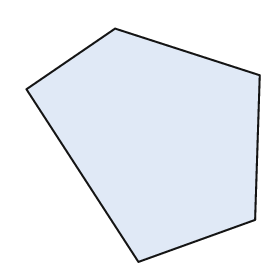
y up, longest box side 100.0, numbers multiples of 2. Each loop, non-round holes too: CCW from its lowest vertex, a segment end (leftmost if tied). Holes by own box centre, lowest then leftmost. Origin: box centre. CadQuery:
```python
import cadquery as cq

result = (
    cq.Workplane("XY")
    .moveTo(-2.0, -50.0)
    .lineTo(48.0, -32.0)
    .lineTo(50.0, 30.0)
    .lineTo(-12.0, 50.0)
    .lineTo(-50.0, 24.0)
    .close()
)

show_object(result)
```